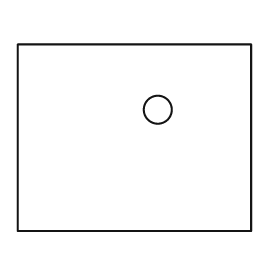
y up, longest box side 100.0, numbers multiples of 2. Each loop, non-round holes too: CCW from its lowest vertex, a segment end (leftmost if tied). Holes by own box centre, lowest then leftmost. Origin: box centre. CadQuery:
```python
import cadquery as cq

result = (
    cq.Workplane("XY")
    .moveTo(-50.0, -40.0)
    .lineTo(50.0, -40.0)
    .lineTo(50.0, 40.0)
    .lineTo(-50.0, 40.0)
    .close()
    .moveTo(10.0, 12.0)
    .circle(6.0)
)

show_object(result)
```